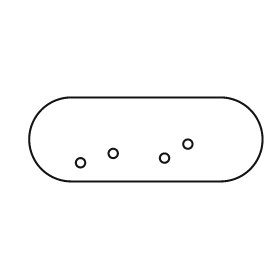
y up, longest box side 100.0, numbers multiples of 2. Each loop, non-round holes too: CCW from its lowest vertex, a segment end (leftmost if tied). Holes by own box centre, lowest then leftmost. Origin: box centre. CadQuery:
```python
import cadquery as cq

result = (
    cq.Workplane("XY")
    .moveTo(-32.0, -18.0)
    .lineTo(32.0, -18.0)
    .threePointArc((50.0, 0.0), (32.0, 18.0))
    .lineTo(-32.0, 18.0)
    .threePointArc((-50.0, 0.0), (-32.0, -18.0))
    .close()
    .moveTo(-28.0, -10.0)
    .circle(2.0)
    .moveTo(8.0, -8.0)
    .circle(2.0)
    .moveTo(-14.0, -6.0)
    .circle(2.0)
    .moveTo(18.0, -2.0)
    .circle(2.0)
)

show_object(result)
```